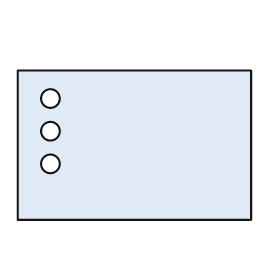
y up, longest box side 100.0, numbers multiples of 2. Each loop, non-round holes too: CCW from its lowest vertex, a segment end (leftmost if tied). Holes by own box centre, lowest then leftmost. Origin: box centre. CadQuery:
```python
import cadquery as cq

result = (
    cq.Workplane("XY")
    .moveTo(-50.0, -32.0)
    .lineTo(50.0, -32.0)
    .lineTo(50.0, 32.0)
    .lineTo(-50.0, 32.0)
    .close()
    .moveTo(-36.0, -8.0)
    .circle(4.0)
    .moveTo(-36.0, 6.0)
    .circle(4.0)
    .moveTo(-36.0, 20.0)
    .circle(4.0)
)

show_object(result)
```